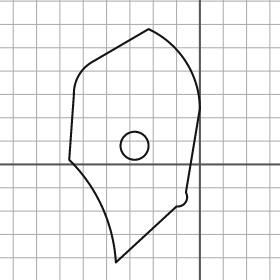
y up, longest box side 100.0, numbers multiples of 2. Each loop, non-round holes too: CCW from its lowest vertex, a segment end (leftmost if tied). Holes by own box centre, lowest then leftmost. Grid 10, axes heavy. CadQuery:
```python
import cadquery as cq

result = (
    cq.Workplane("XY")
    .moveTo(-36.0, -42.0)
    .lineTo(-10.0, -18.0)
    .threePointArc((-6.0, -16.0), (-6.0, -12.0))
    .lineTo(0.0, 24.0)
    .threePointArc((-6.0, 44.0), (-22.0, 58.0))
    .lineTo(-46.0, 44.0)
    .threePointArc((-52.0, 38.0), (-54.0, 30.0))
    .lineTo(-56.0, 2.0)
    .threePointArc((-42.0, -18.0), (-36.0, -42.0))
    .close()
    .moveTo(-28.0, 8.0)
    .circle(6.0)
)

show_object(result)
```